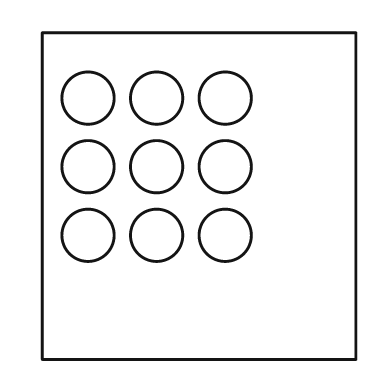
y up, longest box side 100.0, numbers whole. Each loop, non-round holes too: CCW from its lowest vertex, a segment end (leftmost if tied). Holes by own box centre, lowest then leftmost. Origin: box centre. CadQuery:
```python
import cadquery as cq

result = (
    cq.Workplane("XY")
    .moveTo(-48.0, -50.0)
    .lineTo(48.0, -50.0)
    .lineTo(48.0, 50.0)
    .lineTo(-48.0, 50.0)
    .close()
    .moveTo(-34.0, -12.0)
    .circle(8.0)
    .moveTo(-13.0, -12.0)
    .circle(8.0)
    .moveTo(8.0, -12.0)
    .circle(8.0)
    .moveTo(-34.0, 9.0)
    .circle(8.0)
    .moveTo(-13.0, 9.0)
    .circle(8.0)
    .moveTo(8.0, 9.0)
    .circle(8.0)
    .moveTo(-34.0, 30.0)
    .circle(8.0)
    .moveTo(-13.0, 30.0)
    .circle(8.0)
    .moveTo(8.0, 30.0)
    .circle(8.0)
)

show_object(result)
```